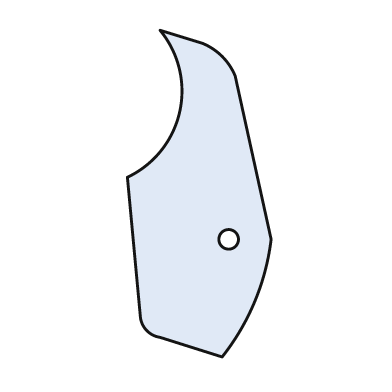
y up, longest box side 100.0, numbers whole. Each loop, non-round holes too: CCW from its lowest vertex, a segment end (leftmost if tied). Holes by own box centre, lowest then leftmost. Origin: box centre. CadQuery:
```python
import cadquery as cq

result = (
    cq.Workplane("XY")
    .moveTo(7.0, -50.0)
    .threePointArc((17.0, -33.0), (22.0, -14.0))
    .lineTo(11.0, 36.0)
    .threePointArc((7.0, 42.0), (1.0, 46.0))
    .lineTo(-12.0, 50.0)
    .threePointArc((-6.0, 25.0), (-22.0, 5.0))
    .lineTo(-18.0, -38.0)
    .threePointArc((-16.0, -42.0), (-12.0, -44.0))
    .close()
    .moveTo(9.0, -14.0)
    .circle(3.0)
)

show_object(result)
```